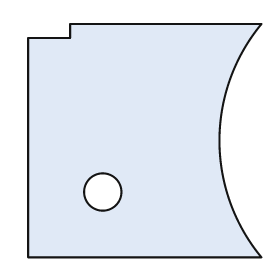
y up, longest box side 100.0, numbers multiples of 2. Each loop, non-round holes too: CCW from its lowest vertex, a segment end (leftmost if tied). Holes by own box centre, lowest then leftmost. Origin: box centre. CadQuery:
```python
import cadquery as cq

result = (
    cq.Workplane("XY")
    .moveTo(-50.0, -50.0)
    .lineTo(50.0, -50.0)
    .threePointArc((32.0, 0.0), (50.0, 50.0))
    .lineTo(-32.0, 50.0)
    .lineTo(-32.0, 44.0)
    .lineTo(-50.0, 44.0)
    .close()
    .moveTo(-18.0, -22.0)
    .circle(8.0)
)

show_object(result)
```